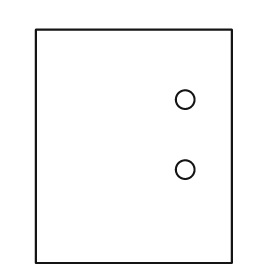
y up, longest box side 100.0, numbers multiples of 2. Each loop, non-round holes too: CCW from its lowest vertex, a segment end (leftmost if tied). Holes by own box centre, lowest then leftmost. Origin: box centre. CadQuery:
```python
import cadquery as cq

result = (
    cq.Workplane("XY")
    .moveTo(-42.0, -50.0)
    .lineTo(42.0, -50.0)
    .lineTo(42.0, 50.0)
    .lineTo(-42.0, 50.0)
    .close()
    .moveTo(22.0, -10.0)
    .circle(4.0)
    .moveTo(22.0, 20.0)
    .circle(4.0)
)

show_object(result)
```